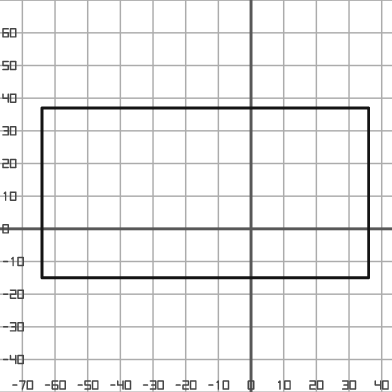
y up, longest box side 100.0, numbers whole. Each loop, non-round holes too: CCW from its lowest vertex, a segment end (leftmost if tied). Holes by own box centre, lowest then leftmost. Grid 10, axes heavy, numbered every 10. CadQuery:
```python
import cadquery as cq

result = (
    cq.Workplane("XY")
    .moveTo(-64.0, -15.0)
    .lineTo(36.0, -15.0)
    .lineTo(36.0, 37.0)
    .lineTo(-64.0, 37.0)
    .close()
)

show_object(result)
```